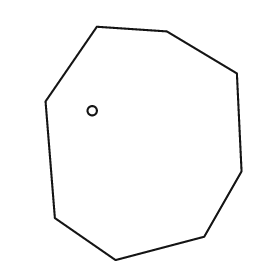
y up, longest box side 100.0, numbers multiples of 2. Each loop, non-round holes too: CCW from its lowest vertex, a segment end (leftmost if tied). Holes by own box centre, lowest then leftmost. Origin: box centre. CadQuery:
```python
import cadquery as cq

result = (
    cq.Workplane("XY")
    .moveTo(-12.0, -50.0)
    .lineTo(26.0, -40.0)
    .lineTo(42.0, -12.0)
    .lineTo(40.0, 30.0)
    .lineTo(10.0, 48.0)
    .lineTo(-20.0, 50.0)
    .lineTo(-42.0, 18.0)
    .lineTo(-38.0, -32.0)
    .close()
    .moveTo(-22.0, 14.0)
    .circle(2.0)
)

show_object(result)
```